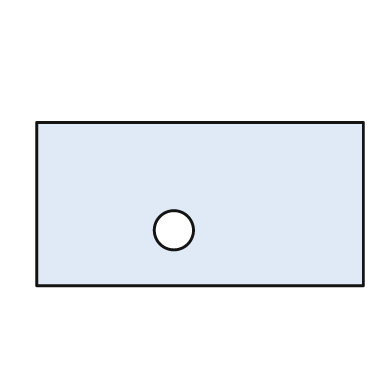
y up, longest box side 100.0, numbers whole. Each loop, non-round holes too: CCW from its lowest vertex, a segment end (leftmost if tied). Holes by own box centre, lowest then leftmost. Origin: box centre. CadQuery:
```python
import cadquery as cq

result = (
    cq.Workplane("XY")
    .moveTo(-50.0, -25.0)
    .lineTo(50.0, -25.0)
    .lineTo(50.0, 25.0)
    .lineTo(-50.0, 25.0)
    .close()
    .moveTo(-8.0, -8.0)
    .circle(6.0)
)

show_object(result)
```